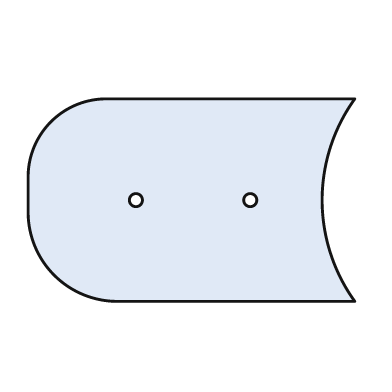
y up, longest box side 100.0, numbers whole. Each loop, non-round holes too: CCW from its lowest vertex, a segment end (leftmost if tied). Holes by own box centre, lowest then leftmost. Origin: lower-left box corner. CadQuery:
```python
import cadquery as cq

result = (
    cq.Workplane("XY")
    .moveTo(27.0, 0.0)
    .lineTo(100.0, 0.0)
    .threePointArc((90.0, 31.0), (100.0, 62.0))
    .lineTo(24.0, 62.0)
    .threePointArc((7.0, 55.0), (0.0, 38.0))
    .lineTo(0.0, 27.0)
    .threePointArc((8.0, 8.0), (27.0, 0.0))
    .close()
    .moveTo(33.0, 31.0)
    .circle(2.0)
    .moveTo(68.0, 31.0)
    .circle(2.0)
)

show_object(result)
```